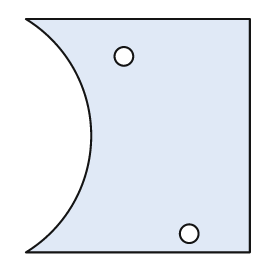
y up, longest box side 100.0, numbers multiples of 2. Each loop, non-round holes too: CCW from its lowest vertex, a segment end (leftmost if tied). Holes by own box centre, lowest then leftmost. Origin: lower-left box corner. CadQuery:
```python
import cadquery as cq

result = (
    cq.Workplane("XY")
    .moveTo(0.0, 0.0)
    .lineTo(96.0, 0.0)
    .lineTo(96.0, 100.0)
    .lineTo(0.0, 100.0)
    .threePointArc((28.0, 50.0), (0.0, 0.0))
    .close()
    .moveTo(70.0, 8.0)
    .circle(4.0)
    .moveTo(42.0, 84.0)
    .circle(4.0)
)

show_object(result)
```